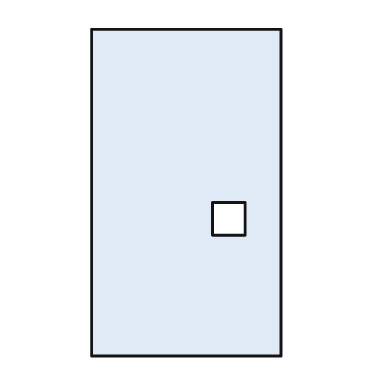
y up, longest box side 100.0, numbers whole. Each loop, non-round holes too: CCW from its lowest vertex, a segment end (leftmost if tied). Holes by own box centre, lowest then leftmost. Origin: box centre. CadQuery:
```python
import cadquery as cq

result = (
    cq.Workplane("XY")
    .moveTo(-29.0, -50.0)
    .lineTo(29.0, -50.0)
    .lineTo(29.0, 50.0)
    .lineTo(-29.0, 50.0)
    .close()
    .moveTo(8.0, -13.0)
    .lineTo(18.0, -13.0)
    .lineTo(18.0, -3.0)
    .lineTo(8.0, -3.0)
    .close()
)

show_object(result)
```